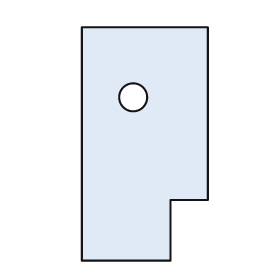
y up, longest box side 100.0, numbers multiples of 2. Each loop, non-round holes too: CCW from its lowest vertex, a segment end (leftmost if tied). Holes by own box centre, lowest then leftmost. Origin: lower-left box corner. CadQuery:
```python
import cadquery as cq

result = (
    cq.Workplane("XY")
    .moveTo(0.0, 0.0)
    .lineTo(38.0, 0.0)
    .lineTo(38.0, 26.0)
    .lineTo(54.0, 26.0)
    .lineTo(54.0, 100.0)
    .lineTo(0.0, 100.0)
    .close()
    .moveTo(22.0, 70.0)
    .circle(6.0)
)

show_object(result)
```